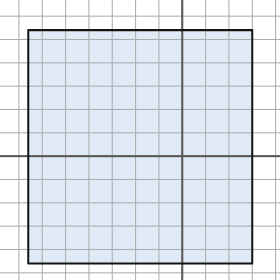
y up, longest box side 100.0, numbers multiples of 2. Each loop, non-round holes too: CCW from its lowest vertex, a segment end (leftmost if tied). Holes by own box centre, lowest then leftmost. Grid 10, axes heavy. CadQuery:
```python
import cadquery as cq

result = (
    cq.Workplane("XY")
    .moveTo(-66.0, -46.0)
    .lineTo(30.0, -46.0)
    .lineTo(30.0, 54.0)
    .lineTo(-66.0, 54.0)
    .close()
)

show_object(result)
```